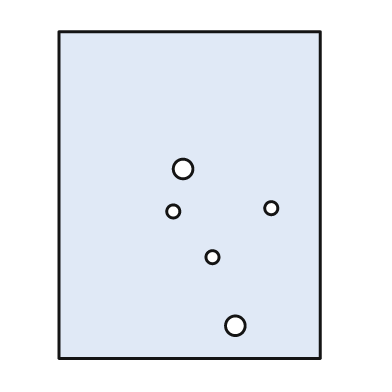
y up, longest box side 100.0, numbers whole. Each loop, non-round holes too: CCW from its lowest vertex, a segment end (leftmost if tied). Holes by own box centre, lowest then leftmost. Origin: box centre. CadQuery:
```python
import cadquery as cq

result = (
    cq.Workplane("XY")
    .moveTo(-40.0, -50.0)
    .lineTo(40.0, -50.0)
    .lineTo(40.0, 50.0)
    .lineTo(-40.0, 50.0)
    .close()
    .moveTo(14.0, -40.0)
    .circle(3.0)
    .moveTo(7.0, -19.0)
    .circle(2.0)
    .moveTo(-5.0, -5.0)
    .circle(2.0)
    .moveTo(25.0, -4.0)
    .circle(2.0)
    .moveTo(-2.0, 8.0)
    .circle(3.0)
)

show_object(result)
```